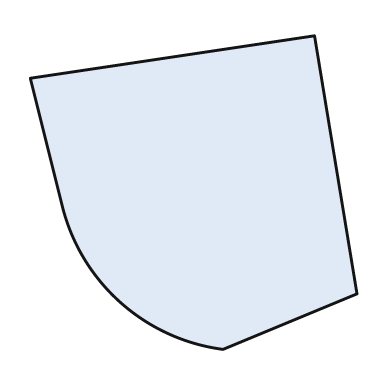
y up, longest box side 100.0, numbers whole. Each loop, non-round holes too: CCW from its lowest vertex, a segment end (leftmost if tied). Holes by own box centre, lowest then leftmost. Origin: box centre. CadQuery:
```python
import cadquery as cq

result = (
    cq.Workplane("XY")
    .moveTo(9.0, -48.0)
    .lineTo(50.0, -31.0)
    .lineTo(37.0, 48.0)
    .lineTo(-50.0, 35.0)
    .lineTo(-40.0, -5.0)
    .threePointArc((-22.0, -34.0), (9.0, -48.0))
    .close()
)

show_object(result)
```